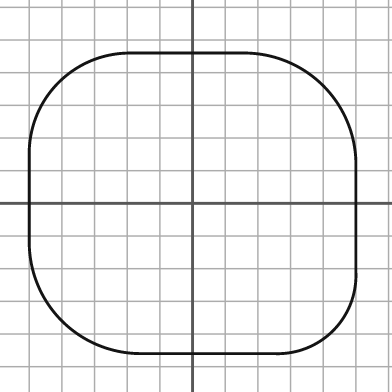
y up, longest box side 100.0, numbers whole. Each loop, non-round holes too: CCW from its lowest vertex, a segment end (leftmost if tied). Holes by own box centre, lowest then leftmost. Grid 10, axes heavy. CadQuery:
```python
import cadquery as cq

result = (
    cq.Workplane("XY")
    .moveTo(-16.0, -46.0)
    .lineTo(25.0, -46.0)
    .threePointArc((43.0, -39.0), (50.0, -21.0))
    .lineTo(50.0, 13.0)
    .threePointArc((40.0, 36.0), (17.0, 46.0))
    .lineTo(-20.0, 46.0)
    .threePointArc((-41.0, 37.0), (-50.0, 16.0))
    .lineTo(-50.0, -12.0)
    .threePointArc((-40.0, -36.0), (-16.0, -46.0))
    .close()
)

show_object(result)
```